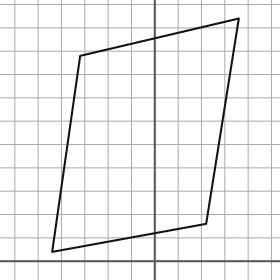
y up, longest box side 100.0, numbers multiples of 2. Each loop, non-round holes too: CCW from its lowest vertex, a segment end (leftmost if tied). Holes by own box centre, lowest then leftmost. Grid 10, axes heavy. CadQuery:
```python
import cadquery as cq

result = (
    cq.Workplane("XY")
    .moveTo(-44.0, 4.0)
    .lineTo(22.0, 16.0)
    .lineTo(36.0, 104.0)
    .lineTo(-32.0, 88.0)
    .close()
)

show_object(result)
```